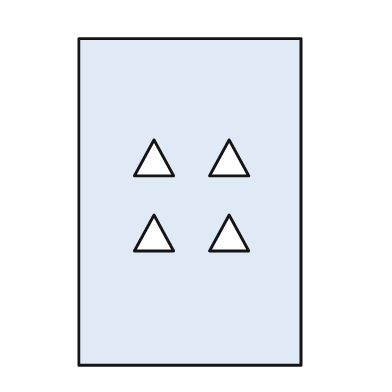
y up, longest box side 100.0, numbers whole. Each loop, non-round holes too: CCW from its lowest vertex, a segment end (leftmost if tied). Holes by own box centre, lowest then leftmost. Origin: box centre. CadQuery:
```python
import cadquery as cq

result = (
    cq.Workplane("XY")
    .moveTo(-34.0, -50.0)
    .lineTo(34.0, -50.0)
    .lineTo(34.0, 50.0)
    .lineTo(-34.0, 50.0)
    .close()
    .moveTo(-17.0, -15.0)
    .lineTo(-5.0, -15.0)
    .lineTo(-11.0, -4.0)
    .close()
    .moveTo(6.0, -15.0)
    .lineTo(18.0, -15.0)
    .lineTo(12.0, -4.0)
    .close()
    .moveTo(-17.0, 8.0)
    .lineTo(-5.0, 8.0)
    .lineTo(-11.0, 19.0)
    .close()
    .moveTo(6.0, 8.0)
    .lineTo(18.0, 8.0)
    .lineTo(12.0, 19.0)
    .close()
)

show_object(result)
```